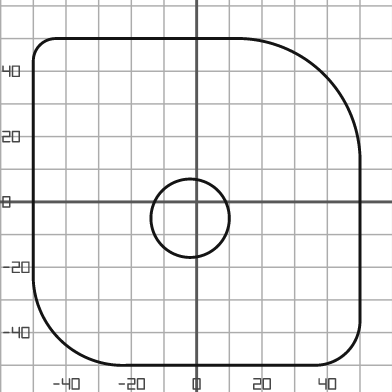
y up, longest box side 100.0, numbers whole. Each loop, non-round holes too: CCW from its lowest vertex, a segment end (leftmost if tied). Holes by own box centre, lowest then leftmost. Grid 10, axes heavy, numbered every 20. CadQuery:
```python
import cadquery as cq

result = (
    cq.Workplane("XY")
    .moveTo(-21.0, -50.0)
    .lineTo(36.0, -50.0)
    .threePointArc((46.0, -46.0), (50.0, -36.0))
    .lineTo(50.0, 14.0)
    .threePointArc((39.0, 39.0), (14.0, 50.0))
    .lineTo(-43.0, 50.0)
    .threePointArc((-48.0, 48.0), (-50.0, 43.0))
    .lineTo(-50.0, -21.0)
    .threePointArc((-42.0, -42.0), (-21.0, -50.0))
    .close()
    .moveTo(-2.0, -5.0)
    .circle(12.0)
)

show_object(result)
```